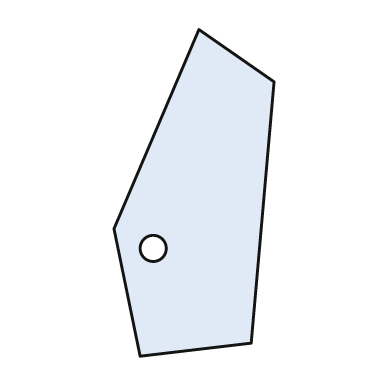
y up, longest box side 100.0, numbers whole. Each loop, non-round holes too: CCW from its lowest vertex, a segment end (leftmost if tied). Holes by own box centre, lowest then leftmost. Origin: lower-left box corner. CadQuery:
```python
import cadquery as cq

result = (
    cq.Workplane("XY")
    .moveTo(8.0, 0.0)
    .lineTo(42.0, 4.0)
    .lineTo(49.0, 84.0)
    .lineTo(26.0, 100.0)
    .lineTo(0.0, 39.0)
    .close()
    .moveTo(12.0, 33.0)
    .circle(4.0)
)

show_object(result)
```